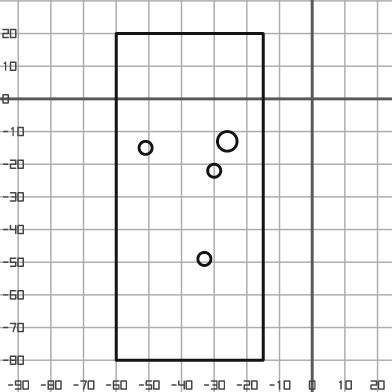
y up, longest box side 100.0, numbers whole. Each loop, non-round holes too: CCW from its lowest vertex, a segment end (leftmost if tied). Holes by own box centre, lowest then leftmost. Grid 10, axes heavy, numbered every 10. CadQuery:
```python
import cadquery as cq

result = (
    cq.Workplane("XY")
    .moveTo(-60.0, -80.0)
    .lineTo(-15.0, -80.0)
    .lineTo(-15.0, 20.0)
    .lineTo(-60.0, 20.0)
    .close()
    .moveTo(-33.0, -49.0)
    .circle(2.0)
    .moveTo(-30.0, -22.0)
    .circle(2.0)
    .moveTo(-51.0, -15.0)
    .circle(2.0)
    .moveTo(-26.0, -13.0)
    .circle(3.0)
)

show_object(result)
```